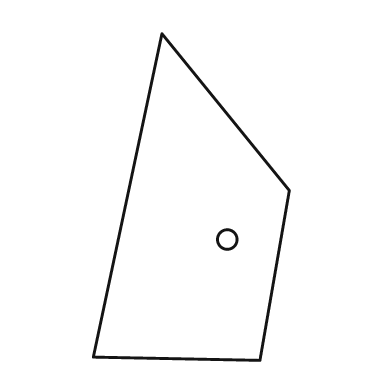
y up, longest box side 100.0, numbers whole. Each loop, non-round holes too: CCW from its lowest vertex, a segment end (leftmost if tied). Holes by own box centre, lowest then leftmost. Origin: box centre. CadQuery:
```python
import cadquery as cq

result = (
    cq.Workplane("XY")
    .moveTo(21.0, -50.0)
    .lineTo(30.0, 2.0)
    .lineTo(-9.0, 50.0)
    .lineTo(-30.0, -49.0)
    .close()
    .moveTo(11.0, -13.0)
    .circle(3.0)
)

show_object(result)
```